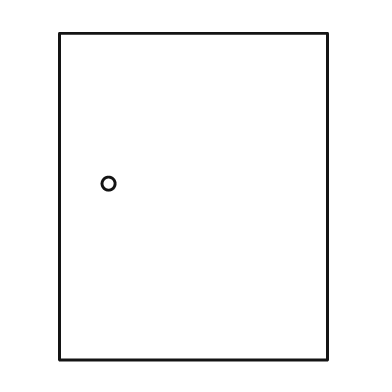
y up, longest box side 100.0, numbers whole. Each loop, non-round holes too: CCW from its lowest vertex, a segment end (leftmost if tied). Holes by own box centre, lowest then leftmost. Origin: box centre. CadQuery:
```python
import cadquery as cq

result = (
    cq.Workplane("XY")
    .moveTo(-41.0, -50.0)
    .lineTo(41.0, -50.0)
    .lineTo(41.0, 50.0)
    .lineTo(-41.0, 50.0)
    .close()
    .moveTo(-26.0, 4.0)
    .circle(2.0)
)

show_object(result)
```